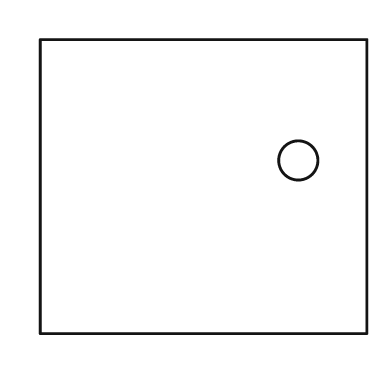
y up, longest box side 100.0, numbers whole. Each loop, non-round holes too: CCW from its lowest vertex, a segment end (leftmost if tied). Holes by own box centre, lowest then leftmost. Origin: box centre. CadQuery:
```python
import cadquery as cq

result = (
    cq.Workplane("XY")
    .moveTo(-50.0, -45.0)
    .lineTo(50.0, -45.0)
    .lineTo(50.0, 45.0)
    .lineTo(-50.0, 45.0)
    .close()
    .moveTo(29.0, 8.0)
    .circle(6.0)
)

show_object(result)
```